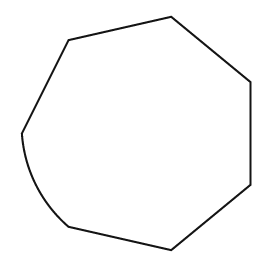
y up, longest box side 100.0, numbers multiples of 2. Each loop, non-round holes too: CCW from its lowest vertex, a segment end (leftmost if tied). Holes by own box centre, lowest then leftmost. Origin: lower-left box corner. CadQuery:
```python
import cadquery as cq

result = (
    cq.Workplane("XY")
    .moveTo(64.0, 0.0)
    .lineTo(98.0, 28.0)
    .lineTo(98.0, 72.0)
    .lineTo(64.0, 100.0)
    .lineTo(20.0, 90.0)
    .lineTo(0.0, 50.0)
    .threePointArc((6.0, 28.0), (20.0, 10.0))
    .close()
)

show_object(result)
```